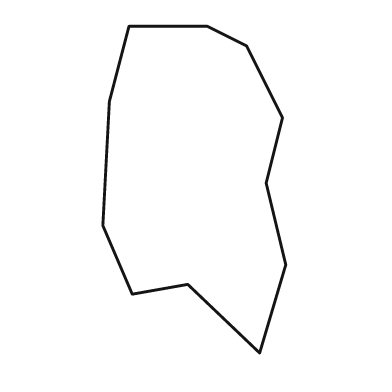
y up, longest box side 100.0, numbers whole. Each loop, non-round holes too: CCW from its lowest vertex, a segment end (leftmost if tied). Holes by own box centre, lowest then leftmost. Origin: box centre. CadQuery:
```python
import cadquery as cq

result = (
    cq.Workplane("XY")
    .moveTo(20.0, -50.0)
    .lineTo(28.0, -23.0)
    .lineTo(22.0, 2.0)
    .lineTo(27.0, 22.0)
    .lineTo(16.0, 44.0)
    .lineTo(4.0, 50.0)
    .lineTo(-20.0, 50.0)
    .lineTo(-26.0, 27.0)
    .lineTo(-28.0, -11.0)
    .lineTo(-19.0, -32.0)
    .lineTo(-2.0, -29.0)
    .close()
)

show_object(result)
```